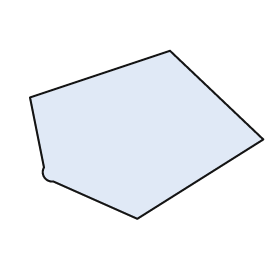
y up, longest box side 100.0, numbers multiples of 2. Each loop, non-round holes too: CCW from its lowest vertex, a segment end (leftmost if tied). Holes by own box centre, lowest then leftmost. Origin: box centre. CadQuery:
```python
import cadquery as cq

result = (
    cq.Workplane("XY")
    .moveTo(-4.0, -36.0)
    .lineTo(50.0, -2.0)
    .lineTo(10.0, 36.0)
    .lineTo(-50.0, 16.0)
    .lineTo(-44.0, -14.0)
    .threePointArc((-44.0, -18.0), (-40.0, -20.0))
    .close()
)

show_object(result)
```